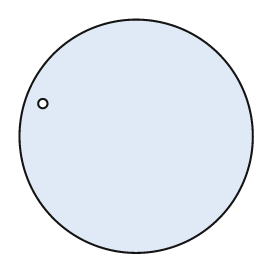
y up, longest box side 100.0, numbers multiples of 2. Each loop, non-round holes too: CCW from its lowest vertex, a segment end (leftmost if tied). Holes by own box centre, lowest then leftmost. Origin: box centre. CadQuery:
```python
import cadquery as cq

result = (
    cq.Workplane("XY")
    .moveTo(0.0, 0.0)
    .circle(50.0)
    .moveTo(-40.0, 14.0)
    .circle(2.0)
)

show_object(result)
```